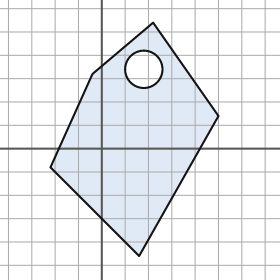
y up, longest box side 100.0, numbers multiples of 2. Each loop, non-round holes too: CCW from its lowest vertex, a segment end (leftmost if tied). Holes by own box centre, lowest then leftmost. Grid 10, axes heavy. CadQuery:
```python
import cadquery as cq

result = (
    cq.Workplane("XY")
    .moveTo(16.0, -46.0)
    .lineTo(50.0, 14.0)
    .lineTo(22.0, 54.0)
    .lineTo(-4.0, 32.0)
    .lineTo(-22.0, -8.0)
    .close()
    .moveTo(18.0, 34.0)
    .circle(8.0)
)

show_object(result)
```